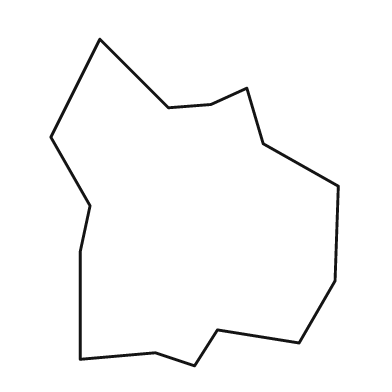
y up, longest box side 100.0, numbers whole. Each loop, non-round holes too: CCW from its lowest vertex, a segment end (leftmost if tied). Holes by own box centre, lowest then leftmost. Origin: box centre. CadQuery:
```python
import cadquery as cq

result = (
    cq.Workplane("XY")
    .moveTo(0.0, -50.0)
    .lineTo(7.0, -39.0)
    .lineTo(32.0, -43.0)
    .lineTo(43.0, -24.0)
    .lineTo(44.0, 5.0)
    .lineTo(21.0, 18.0)
    .lineTo(16.0, 35.0)
    .lineTo(5.0, 30.0)
    .lineTo(-8.0, 29.0)
    .lineTo(-29.0, 50.0)
    .lineTo(-44.0, 20.0)
    .lineTo(-32.0, -1.0)
    .lineTo(-35.0, -15.0)
    .lineTo(-35.0, -48.0)
    .lineTo(-12.0, -46.0)
    .close()
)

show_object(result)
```